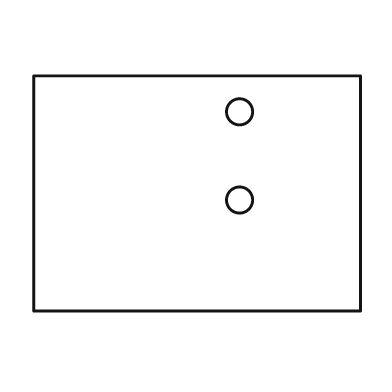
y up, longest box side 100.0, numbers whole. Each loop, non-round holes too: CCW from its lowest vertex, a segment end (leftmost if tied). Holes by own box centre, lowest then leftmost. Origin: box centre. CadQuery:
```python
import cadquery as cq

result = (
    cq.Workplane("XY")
    .moveTo(-50.0, -36.0)
    .lineTo(50.0, -36.0)
    .lineTo(50.0, 36.0)
    .lineTo(-50.0, 36.0)
    .close()
    .moveTo(13.0, -2.0)
    .circle(4.0)
    .moveTo(13.0, 25.0)
    .circle(4.0)
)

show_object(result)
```